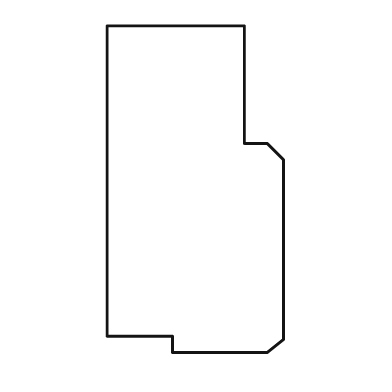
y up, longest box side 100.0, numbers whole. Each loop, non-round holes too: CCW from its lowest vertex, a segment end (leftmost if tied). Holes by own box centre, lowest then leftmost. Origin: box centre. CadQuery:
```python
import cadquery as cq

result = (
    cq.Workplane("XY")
    .moveTo(-7.0, -50.0)
    .lineTo(22.0, -50.0)
    .lineTo(27.0, -46.0)
    .lineTo(27.0, 9.0)
    .lineTo(22.0, 14.0)
    .lineTo(15.0, 14.0)
    .lineTo(15.0, 50.0)
    .lineTo(-27.0, 50.0)
    .lineTo(-27.0, -45.0)
    .lineTo(-7.0, -45.0)
    .close()
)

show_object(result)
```